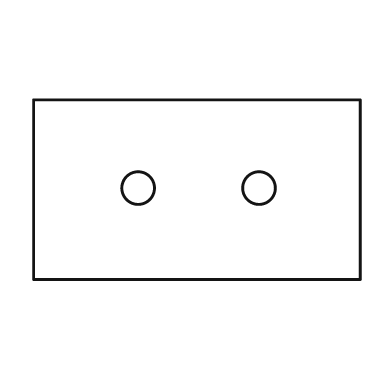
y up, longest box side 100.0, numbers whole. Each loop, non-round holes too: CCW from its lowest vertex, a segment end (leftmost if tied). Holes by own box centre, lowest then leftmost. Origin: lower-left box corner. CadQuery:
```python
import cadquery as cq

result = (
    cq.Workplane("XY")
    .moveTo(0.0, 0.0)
    .lineTo(100.0, 0.0)
    .lineTo(100.0, 55.0)
    .lineTo(0.0, 55.0)
    .close()
    .moveTo(32.0, 28.0)
    .circle(5.0)
    .moveTo(69.0, 28.0)
    .circle(5.0)
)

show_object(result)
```